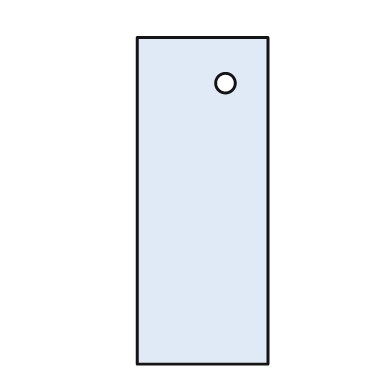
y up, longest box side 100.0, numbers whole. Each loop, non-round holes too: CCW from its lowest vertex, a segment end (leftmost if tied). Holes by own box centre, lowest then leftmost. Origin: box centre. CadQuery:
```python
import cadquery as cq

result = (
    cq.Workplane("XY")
    .moveTo(-20.0, -50.0)
    .lineTo(20.0, -50.0)
    .lineTo(20.0, 50.0)
    .lineTo(-20.0, 50.0)
    .close()
    .moveTo(7.0, 36.0)
    .circle(3.0)
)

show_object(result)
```